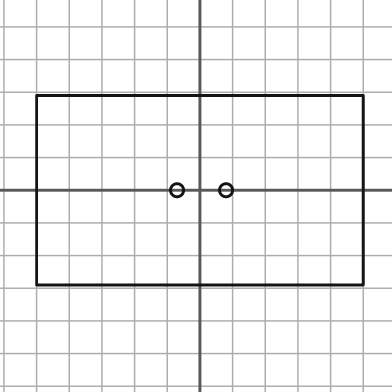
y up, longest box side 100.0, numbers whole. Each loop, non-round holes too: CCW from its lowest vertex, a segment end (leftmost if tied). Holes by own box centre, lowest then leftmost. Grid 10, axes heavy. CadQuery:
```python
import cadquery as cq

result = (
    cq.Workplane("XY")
    .moveTo(-50.0, -29.0)
    .lineTo(50.0, -29.0)
    .lineTo(50.0, 29.0)
    .lineTo(-50.0, 29.0)
    .close()
    .moveTo(-7.0, 0.0)
    .circle(2.0)
    .moveTo(8.0, 0.0)
    .circle(2.0)
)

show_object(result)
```